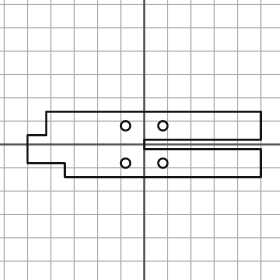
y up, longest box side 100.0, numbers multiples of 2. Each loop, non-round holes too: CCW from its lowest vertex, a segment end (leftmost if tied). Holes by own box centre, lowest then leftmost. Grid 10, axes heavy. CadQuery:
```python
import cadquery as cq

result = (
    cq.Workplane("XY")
    .moveTo(-34.0, -14.0)
    .lineTo(50.0, -14.0)
    .lineTo(50.0, -2.0)
    .lineTo(0.0, -2.0)
    .lineTo(0.0, 2.0)
    .lineTo(50.0, 2.0)
    .lineTo(50.0, 14.0)
    .lineTo(-42.0, 14.0)
    .lineTo(-42.0, 4.0)
    .lineTo(-50.0, 4.0)
    .lineTo(-50.0, -8.0)
    .lineTo(-34.0, -8.0)
    .close()
    .moveTo(-8.0, -8.0)
    .circle(2.0)
    .moveTo(8.0, -8.0)
    .circle(2.0)
    .moveTo(-8.0, 8.0)
    .circle(2.0)
    .moveTo(8.0, 8.0)
    .circle(2.0)
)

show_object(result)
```